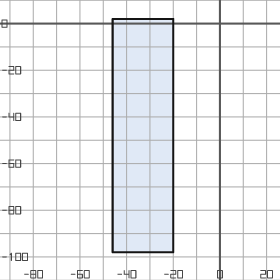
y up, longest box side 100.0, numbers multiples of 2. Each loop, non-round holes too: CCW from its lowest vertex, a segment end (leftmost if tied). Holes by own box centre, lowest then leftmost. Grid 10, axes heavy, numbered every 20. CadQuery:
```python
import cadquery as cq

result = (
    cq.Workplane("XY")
    .moveTo(-46.0, -98.0)
    .lineTo(-20.0, -98.0)
    .lineTo(-20.0, 2.0)
    .lineTo(-46.0, 2.0)
    .close()
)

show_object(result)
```